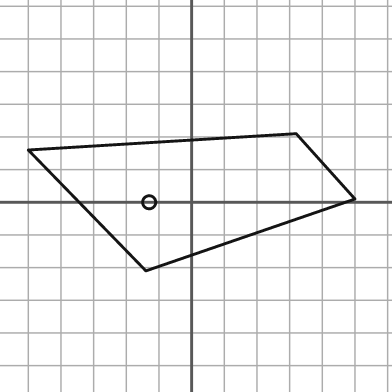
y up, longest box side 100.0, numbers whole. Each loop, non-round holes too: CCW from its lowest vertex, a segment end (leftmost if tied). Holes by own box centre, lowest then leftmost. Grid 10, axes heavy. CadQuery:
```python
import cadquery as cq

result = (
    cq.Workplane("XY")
    .moveTo(-14.0, -21.0)
    .lineTo(50.0, 1.0)
    .lineTo(32.0, 21.0)
    .lineTo(-50.0, 16.0)
    .close()
    .moveTo(-13.0, 0.0)
    .circle(2.0)
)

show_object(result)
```